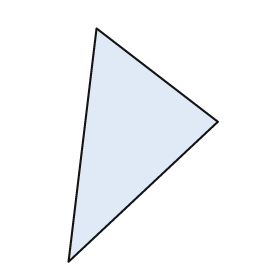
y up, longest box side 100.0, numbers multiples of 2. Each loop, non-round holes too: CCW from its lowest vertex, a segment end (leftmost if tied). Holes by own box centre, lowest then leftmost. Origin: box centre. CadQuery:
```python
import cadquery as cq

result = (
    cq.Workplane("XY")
    .moveTo(-32.0, -50.0)
    .lineTo(32.0, 10.0)
    .lineTo(-20.0, 50.0)
    .close()
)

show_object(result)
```